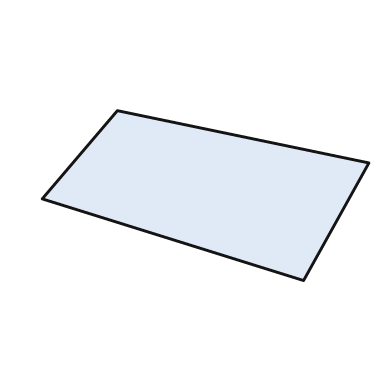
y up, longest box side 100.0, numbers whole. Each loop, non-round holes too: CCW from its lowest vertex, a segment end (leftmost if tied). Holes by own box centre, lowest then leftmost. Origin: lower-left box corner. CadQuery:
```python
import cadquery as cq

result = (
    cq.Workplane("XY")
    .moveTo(80.0, 0.0)
    .lineTo(100.0, 36.0)
    .lineTo(23.0, 52.0)
    .lineTo(0.0, 25.0)
    .close()
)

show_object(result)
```